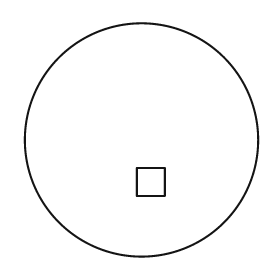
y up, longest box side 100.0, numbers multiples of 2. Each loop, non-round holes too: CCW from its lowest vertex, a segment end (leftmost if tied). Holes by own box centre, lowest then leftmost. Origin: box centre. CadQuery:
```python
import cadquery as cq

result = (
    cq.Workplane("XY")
    .moveTo(0.0, 0.0)
    .circle(50.0)
    .moveTo(-2.0, -24.0)
    .lineTo(10.0, -24.0)
    .lineTo(10.0, -12.0)
    .lineTo(-2.0, -12.0)
    .close()
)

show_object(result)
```